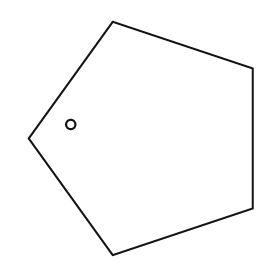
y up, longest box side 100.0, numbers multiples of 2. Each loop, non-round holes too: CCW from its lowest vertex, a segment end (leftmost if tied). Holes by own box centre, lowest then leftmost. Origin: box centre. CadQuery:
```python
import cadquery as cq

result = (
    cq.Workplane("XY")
    .moveTo(-12.0, -50.0)
    .lineTo(48.0, -30.0)
    .lineTo(48.0, 30.0)
    .lineTo(-12.0, 50.0)
    .lineTo(-48.0, 0.0)
    .close()
    .moveTo(-30.0, 6.0)
    .circle(2.0)
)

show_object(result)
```